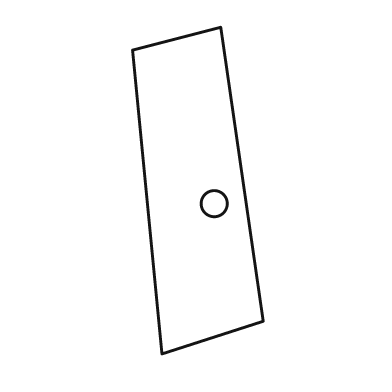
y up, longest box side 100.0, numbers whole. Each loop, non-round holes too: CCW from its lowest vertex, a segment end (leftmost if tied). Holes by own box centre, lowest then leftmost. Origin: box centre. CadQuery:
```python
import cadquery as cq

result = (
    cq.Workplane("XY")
    .moveTo(-11.0, -50.0)
    .lineTo(20.0, -40.0)
    .lineTo(7.0, 50.0)
    .lineTo(-20.0, 43.0)
    .close()
    .moveTo(5.0, -4.0)
    .circle(4.0)
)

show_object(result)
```